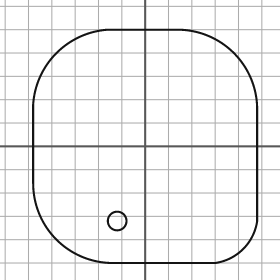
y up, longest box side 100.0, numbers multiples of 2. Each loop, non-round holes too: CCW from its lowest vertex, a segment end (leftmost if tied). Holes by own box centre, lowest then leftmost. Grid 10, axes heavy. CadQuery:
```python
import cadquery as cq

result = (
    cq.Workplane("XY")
    .moveTo(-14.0, -50.0)
    .lineTo(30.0, -50.0)
    .threePointArc((42.0, -44.0), (48.0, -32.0))
    .lineTo(48.0, 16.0)
    .threePointArc((38.0, 40.0), (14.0, 50.0))
    .lineTo(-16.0, 50.0)
    .threePointArc((-38.0, 40.0), (-48.0, 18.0))
    .lineTo(-48.0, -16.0)
    .threePointArc((-38.0, -40.0), (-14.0, -50.0))
    .close()
    .moveTo(-12.0, -32.0)
    .circle(4.0)
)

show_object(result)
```